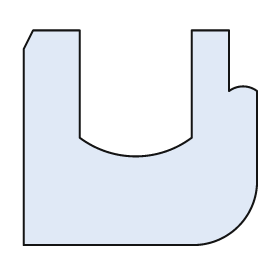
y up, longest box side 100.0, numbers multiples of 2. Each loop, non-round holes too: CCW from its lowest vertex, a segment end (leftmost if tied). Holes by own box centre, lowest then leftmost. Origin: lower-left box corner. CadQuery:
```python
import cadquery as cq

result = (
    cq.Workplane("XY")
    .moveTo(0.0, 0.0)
    .lineTo(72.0, 0.0)
    .threePointArc((92.0, 8.0), (100.0, 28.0))
    .lineTo(100.0, 66.0)
    .threePointArc((94.0, 68.0), (88.0, 66.0))
    .lineTo(88.0, 92.0)
    .lineTo(72.0, 92.0)
    .lineTo(72.0, 46.0)
    .threePointArc((48.0, 38.0), (24.0, 46.0))
    .lineTo(24.0, 92.0)
    .lineTo(4.0, 92.0)
    .lineTo(0.0, 84.0)
    .close()
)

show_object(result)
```